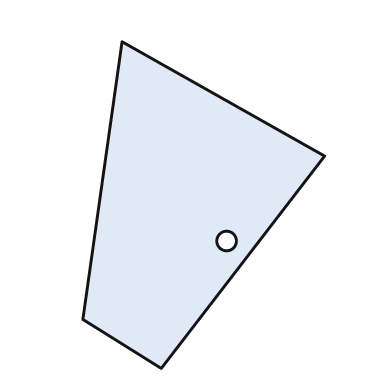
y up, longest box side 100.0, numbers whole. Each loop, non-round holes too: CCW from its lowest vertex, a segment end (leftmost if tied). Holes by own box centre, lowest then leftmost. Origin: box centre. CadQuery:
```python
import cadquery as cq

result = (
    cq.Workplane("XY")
    .moveTo(-13.0, -50.0)
    .lineTo(37.0, 15.0)
    .lineTo(-25.0, 50.0)
    .lineTo(-37.0, -35.0)
    .close()
    .moveTo(7.0, -11.0)
    .circle(3.0)
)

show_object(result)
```